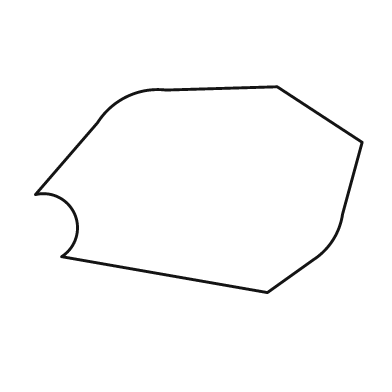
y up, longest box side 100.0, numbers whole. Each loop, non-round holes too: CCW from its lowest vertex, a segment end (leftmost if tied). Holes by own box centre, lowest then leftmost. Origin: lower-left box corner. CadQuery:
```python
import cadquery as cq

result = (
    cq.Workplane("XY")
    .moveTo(71.0, 0.0)
    .lineTo(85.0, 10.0)
    .threePointArc((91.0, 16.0), (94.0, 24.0))
    .lineTo(100.0, 46.0)
    .lineTo(74.0, 63.0)
    .lineTo(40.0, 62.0)
    .threePointArc((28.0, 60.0), (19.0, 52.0))
    .lineTo(0.0, 30.0)
    .threePointArc((12.0, 24.0), (8.0, 11.0))
    .close()
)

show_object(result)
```